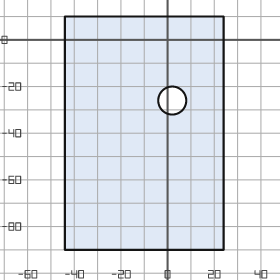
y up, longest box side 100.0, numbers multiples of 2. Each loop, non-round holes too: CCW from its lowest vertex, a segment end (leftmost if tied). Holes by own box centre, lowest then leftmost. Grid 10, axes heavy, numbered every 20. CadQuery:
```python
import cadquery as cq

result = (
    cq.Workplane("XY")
    .moveTo(-44.0, -90.0)
    .lineTo(24.0, -90.0)
    .lineTo(24.0, 10.0)
    .lineTo(-44.0, 10.0)
    .close()
    .moveTo(2.0, -26.0)
    .circle(6.0)
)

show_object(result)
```